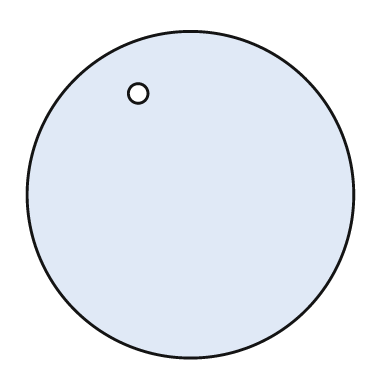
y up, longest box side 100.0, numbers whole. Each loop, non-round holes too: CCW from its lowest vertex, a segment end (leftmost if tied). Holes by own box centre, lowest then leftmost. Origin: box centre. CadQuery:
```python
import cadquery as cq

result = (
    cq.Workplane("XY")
    .moveTo(0.0, 0.0)
    .circle(50.0)
    .moveTo(-16.0, 31.0)
    .circle(3.0)
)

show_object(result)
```